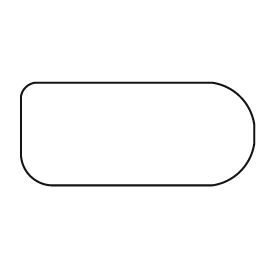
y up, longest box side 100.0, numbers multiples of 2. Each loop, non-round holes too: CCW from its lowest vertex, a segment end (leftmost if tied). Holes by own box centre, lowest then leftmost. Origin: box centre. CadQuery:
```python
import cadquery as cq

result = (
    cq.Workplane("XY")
    .moveTo(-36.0, -22.0)
    .lineTo(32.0, -22.0)
    .threePointArc((44.0, -16.0), (50.0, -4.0))
    .lineTo(50.0, 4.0)
    .threePointArc((44.0, 16.0), (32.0, 22.0))
    .lineTo(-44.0, 22.0)
    .threePointArc((-48.0, 20.0), (-50.0, 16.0))
    .lineTo(-50.0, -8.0)
    .threePointArc((-46.0, -18.0), (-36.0, -22.0))
    .close()
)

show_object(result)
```